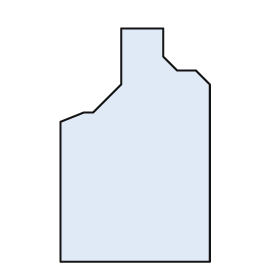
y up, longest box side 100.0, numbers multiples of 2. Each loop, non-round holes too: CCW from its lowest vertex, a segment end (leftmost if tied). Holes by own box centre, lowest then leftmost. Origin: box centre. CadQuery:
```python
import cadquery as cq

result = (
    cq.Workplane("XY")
    .moveTo(-32.0, -50.0)
    .lineTo(32.0, -50.0)
    .lineTo(32.0, 26.0)
    .lineTo(26.0, 32.0)
    .lineTo(18.0, 32.0)
    .lineTo(12.0, 38.0)
    .lineTo(12.0, 50.0)
    .lineTo(-6.0, 50.0)
    .lineTo(-6.0, 26.0)
    .lineTo(-18.0, 14.0)
    .lineTo(-22.0, 14.0)
    .lineTo(-32.0, 10.0)
    .close()
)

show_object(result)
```